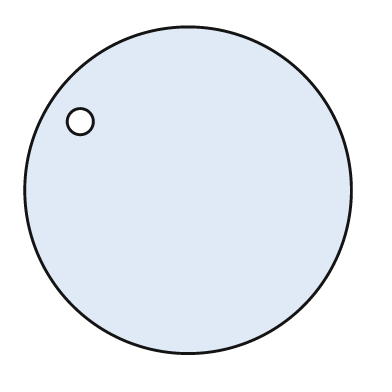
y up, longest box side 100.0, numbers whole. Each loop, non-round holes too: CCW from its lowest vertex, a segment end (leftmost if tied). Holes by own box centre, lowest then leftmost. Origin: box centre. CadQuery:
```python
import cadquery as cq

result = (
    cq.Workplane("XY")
    .moveTo(0.0, 0.0)
    .circle(50.0)
    .moveTo(-33.0, 21.0)
    .circle(4.0)
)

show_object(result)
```